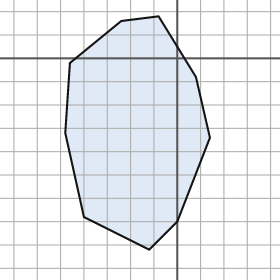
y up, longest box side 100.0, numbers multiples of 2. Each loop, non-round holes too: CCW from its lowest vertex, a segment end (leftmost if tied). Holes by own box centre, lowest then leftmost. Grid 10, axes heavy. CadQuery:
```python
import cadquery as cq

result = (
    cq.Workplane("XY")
    .moveTo(-12.0, -82.0)
    .lineTo(0.0, -70.0)
    .lineTo(14.0, -34.0)
    .lineTo(8.0, -8.0)
    .lineTo(-8.0, 18.0)
    .lineTo(-24.0, 16.0)
    .lineTo(-46.0, -2.0)
    .lineTo(-48.0, -32.0)
    .lineTo(-40.0, -68.0)
    .close()
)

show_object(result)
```